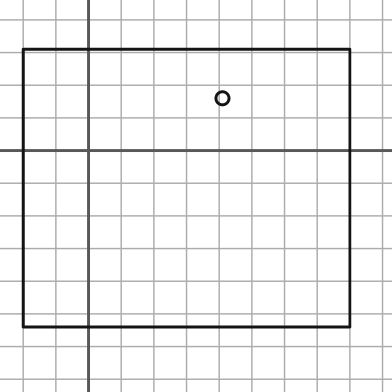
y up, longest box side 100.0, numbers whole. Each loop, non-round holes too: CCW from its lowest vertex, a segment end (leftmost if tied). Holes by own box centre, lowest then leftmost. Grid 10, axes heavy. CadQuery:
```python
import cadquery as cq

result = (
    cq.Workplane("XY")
    .moveTo(-20.0, -54.0)
    .lineTo(80.0, -54.0)
    .lineTo(80.0, 31.0)
    .lineTo(-20.0, 31.0)
    .close()
    .moveTo(41.0, 16.0)
    .circle(2.0)
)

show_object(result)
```